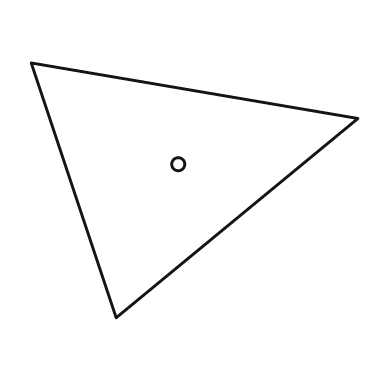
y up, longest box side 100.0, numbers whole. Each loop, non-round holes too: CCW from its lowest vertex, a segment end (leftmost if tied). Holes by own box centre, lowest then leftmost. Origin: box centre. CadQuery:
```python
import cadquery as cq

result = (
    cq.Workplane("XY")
    .moveTo(-24.0, -39.0)
    .lineTo(50.0, 22.0)
    .lineTo(-50.0, 39.0)
    .close()
    .moveTo(-5.0, 8.0)
    .circle(2.0)
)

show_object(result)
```